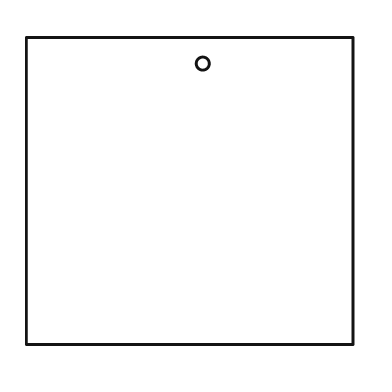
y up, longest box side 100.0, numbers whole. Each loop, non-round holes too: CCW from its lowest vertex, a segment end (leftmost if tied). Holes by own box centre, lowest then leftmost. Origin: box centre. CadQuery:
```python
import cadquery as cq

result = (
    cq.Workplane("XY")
    .moveTo(-50.0, -47.0)
    .lineTo(50.0, -47.0)
    .lineTo(50.0, 47.0)
    .lineTo(-50.0, 47.0)
    .close()
    .moveTo(4.0, 39.0)
    .circle(2.0)
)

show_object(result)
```